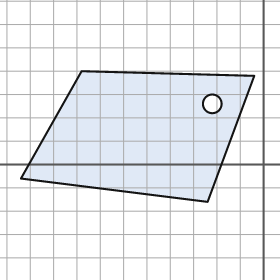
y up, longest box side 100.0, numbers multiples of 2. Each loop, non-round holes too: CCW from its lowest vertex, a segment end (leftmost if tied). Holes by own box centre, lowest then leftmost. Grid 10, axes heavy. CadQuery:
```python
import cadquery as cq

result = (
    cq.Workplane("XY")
    .moveTo(-24.0, -16.0)
    .lineTo(-4.0, 38.0)
    .lineTo(-78.0, 40.0)
    .lineTo(-104.0, -6.0)
    .close()
    .moveTo(-22.0, 26.0)
    .circle(4.0)
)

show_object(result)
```